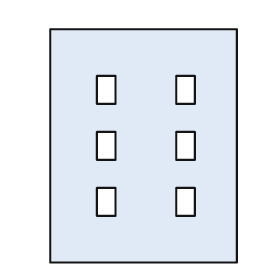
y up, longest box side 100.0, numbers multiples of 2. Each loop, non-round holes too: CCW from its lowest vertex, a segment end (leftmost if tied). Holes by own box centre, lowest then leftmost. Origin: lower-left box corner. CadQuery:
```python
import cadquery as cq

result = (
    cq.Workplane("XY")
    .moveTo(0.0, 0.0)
    .lineTo(80.0, 0.0)
    .lineTo(80.0, 100.0)
    .lineTo(0.0, 100.0)
    .close()
    .moveTo(20.0, 20.0)
    .lineTo(28.0, 20.0)
    .lineTo(28.0, 32.0)
    .lineTo(20.0, 32.0)
    .close()
    .moveTo(54.0, 20.0)
    .lineTo(62.0, 20.0)
    .lineTo(62.0, 32.0)
    .lineTo(54.0, 32.0)
    .close()
    .moveTo(20.0, 44.0)
    .lineTo(28.0, 44.0)
    .lineTo(28.0, 56.0)
    .lineTo(20.0, 56.0)
    .close()
    .moveTo(54.0, 44.0)
    .lineTo(62.0, 44.0)
    .lineTo(62.0, 56.0)
    .lineTo(54.0, 56.0)
    .close()
    .moveTo(20.0, 68.0)
    .lineTo(28.0, 68.0)
    .lineTo(28.0, 80.0)
    .lineTo(20.0, 80.0)
    .close()
    .moveTo(54.0, 68.0)
    .lineTo(62.0, 68.0)
    .lineTo(62.0, 80.0)
    .lineTo(54.0, 80.0)
    .close()
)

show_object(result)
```